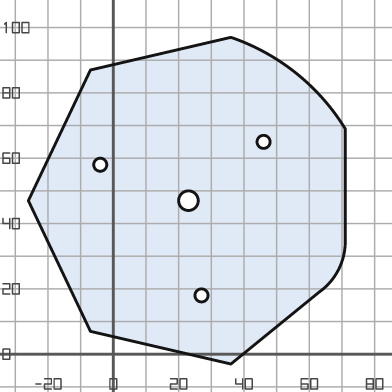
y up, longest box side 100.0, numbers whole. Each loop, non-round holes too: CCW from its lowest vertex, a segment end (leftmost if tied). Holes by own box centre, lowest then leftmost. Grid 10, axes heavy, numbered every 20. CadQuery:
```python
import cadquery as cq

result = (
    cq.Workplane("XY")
    .moveTo(36.0, -3.0)
    .lineTo(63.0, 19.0)
    .threePointArc((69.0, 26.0), (71.0, 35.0))
    .lineTo(71.0, 69.0)
    .threePointArc((56.0, 86.0), (36.0, 97.0))
    .lineTo(-7.0, 87.0)
    .lineTo(-26.0, 47.0)
    .lineTo(-7.0, 7.0)
    .close()
    .moveTo(27.0, 18.0)
    .circle(2.0)
    .moveTo(23.0, 47.0)
    .circle(3.0)
    .moveTo(-4.0, 58.0)
    .circle(2.0)
    .moveTo(46.0, 65.0)
    .circle(2.0)
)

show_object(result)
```